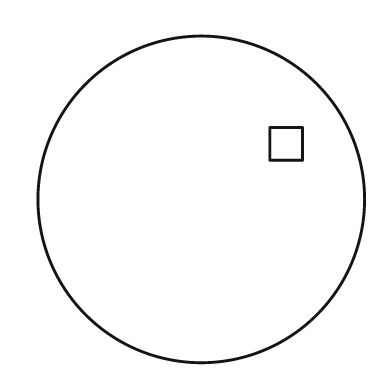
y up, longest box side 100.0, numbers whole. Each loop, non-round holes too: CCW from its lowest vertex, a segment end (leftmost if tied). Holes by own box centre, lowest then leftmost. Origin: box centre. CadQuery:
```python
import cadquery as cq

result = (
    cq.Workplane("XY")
    .moveTo(0.0, 0.0)
    .circle(50.0)
    .moveTo(21.0, 12.0)
    .lineTo(31.0, 12.0)
    .lineTo(31.0, 22.0)
    .lineTo(21.0, 22.0)
    .close()
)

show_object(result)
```